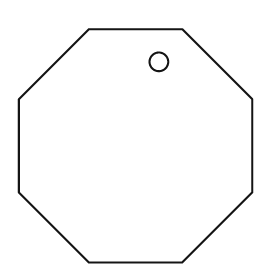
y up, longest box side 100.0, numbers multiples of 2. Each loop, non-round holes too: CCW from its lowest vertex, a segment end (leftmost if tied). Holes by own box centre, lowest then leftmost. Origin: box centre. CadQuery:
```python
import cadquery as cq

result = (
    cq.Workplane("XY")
    .moveTo(-20.0, -50.0)
    .lineTo(20.0, -50.0)
    .lineTo(50.0, -20.0)
    .lineTo(50.0, 20.0)
    .lineTo(20.0, 50.0)
    .lineTo(-20.0, 50.0)
    .lineTo(-50.0, 20.0)
    .lineTo(-50.0, -20.0)
    .close()
    .moveTo(10.0, 36.0)
    .circle(4.0)
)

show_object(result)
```